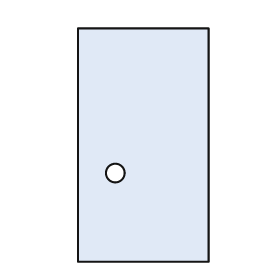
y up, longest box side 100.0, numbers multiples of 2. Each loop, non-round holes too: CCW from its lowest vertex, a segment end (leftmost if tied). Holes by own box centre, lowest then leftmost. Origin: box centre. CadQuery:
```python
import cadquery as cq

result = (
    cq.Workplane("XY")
    .moveTo(-28.0, -50.0)
    .lineTo(28.0, -50.0)
    .lineTo(28.0, 50.0)
    .lineTo(-28.0, 50.0)
    .close()
    .moveTo(-12.0, -12.0)
    .circle(4.0)
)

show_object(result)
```